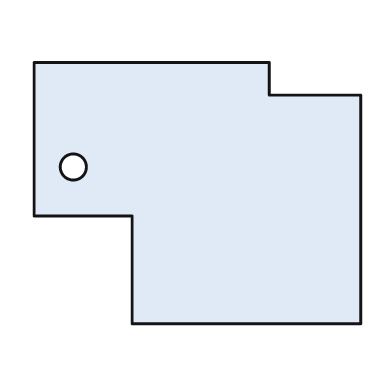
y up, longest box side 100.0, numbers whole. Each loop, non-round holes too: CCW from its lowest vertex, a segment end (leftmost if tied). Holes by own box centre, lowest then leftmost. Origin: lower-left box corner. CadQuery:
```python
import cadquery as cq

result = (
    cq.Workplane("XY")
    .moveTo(30.0, 0.0)
    .lineTo(100.0, 0.0)
    .lineTo(100.0, 70.0)
    .lineTo(72.0, 70.0)
    .lineTo(72.0, 80.0)
    .lineTo(0.0, 80.0)
    .lineTo(0.0, 33.0)
    .lineTo(30.0, 33.0)
    .close()
    .moveTo(12.0, 48.0)
    .circle(4.0)
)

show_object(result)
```